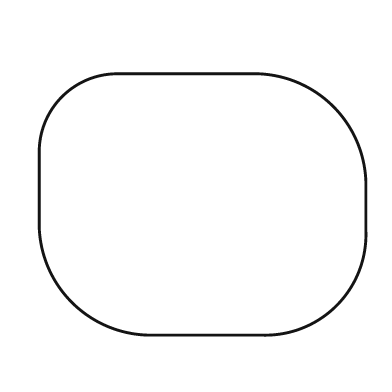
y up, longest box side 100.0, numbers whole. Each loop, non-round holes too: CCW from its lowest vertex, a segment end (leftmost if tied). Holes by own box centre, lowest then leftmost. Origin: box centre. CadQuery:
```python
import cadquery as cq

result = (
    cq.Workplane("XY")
    .moveTo(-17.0, -40.0)
    .lineTo(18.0, -40.0)
    .threePointArc((41.0, -31.0), (50.0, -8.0))
    .lineTo(50.0, 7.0)
    .threePointArc((40.0, 30.0), (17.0, 40.0))
    .lineTo(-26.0, 40.0)
    .threePointArc((-43.0, 33.0), (-50.0, 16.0))
    .lineTo(-50.0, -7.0)
    .threePointArc((-40.0, -30.0), (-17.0, -40.0))
    .close()
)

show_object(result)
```